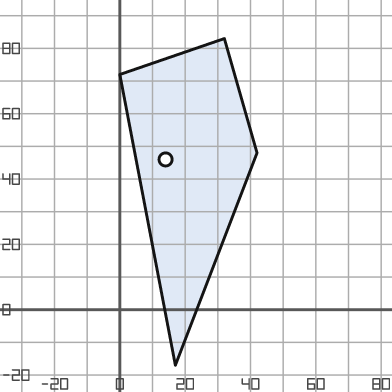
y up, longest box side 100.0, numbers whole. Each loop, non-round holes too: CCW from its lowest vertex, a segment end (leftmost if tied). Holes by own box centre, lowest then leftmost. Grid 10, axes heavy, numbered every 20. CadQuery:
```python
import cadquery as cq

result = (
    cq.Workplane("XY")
    .moveTo(17.0, -17.0)
    .lineTo(42.0, 48.0)
    .lineTo(32.0, 83.0)
    .lineTo(0.0, 72.0)
    .close()
    .moveTo(14.0, 46.0)
    .circle(2.0)
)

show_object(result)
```